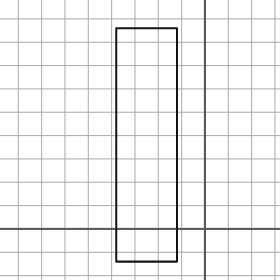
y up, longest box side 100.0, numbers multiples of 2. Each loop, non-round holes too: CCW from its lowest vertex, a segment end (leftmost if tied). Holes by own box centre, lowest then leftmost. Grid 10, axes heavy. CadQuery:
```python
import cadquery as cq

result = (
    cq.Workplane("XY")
    .moveTo(-38.0, -14.0)
    .lineTo(-12.0, -14.0)
    .lineTo(-12.0, 86.0)
    .lineTo(-38.0, 86.0)
    .close()
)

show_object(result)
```